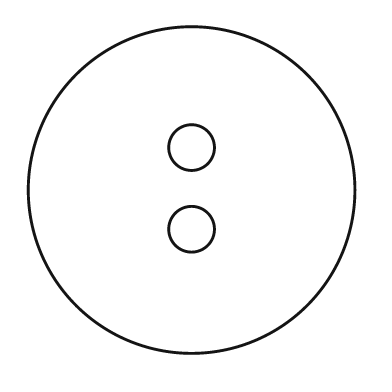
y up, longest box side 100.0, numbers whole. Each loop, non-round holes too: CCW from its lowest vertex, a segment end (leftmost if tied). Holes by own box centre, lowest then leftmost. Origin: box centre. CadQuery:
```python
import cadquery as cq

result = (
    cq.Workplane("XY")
    .moveTo(0.0, 0.0)
    .circle(50.0)
    .moveTo(0.0, -12.0)
    .circle(7.0)
    .moveTo(0.0, 13.0)
    .circle(7.0)
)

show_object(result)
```